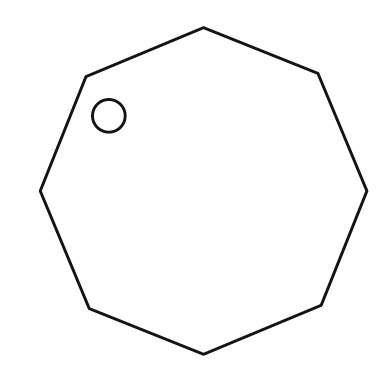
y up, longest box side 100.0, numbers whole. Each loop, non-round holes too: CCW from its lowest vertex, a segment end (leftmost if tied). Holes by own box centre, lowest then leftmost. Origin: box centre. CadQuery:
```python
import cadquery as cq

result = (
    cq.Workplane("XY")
    .moveTo(0.0, -50.0)
    .lineTo(36.0, -35.0)
    .lineTo(50.0, 0.0)
    .lineTo(35.0, 36.0)
    .lineTo(0.0, 50.0)
    .lineTo(-36.0, 35.0)
    .lineTo(-50.0, 0.0)
    .lineTo(-35.0, -36.0)
    .close()
    .moveTo(-29.0, 23.0)
    .circle(5.0)
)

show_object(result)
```